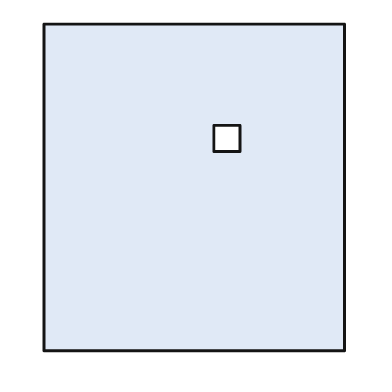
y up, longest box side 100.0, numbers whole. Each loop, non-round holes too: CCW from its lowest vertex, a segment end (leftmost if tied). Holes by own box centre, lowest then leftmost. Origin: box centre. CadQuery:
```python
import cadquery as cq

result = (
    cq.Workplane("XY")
    .moveTo(-46.0, -50.0)
    .lineTo(46.0, -50.0)
    .lineTo(46.0, 50.0)
    .lineTo(-46.0, 50.0)
    .close()
    .moveTo(6.0, 11.0)
    .lineTo(14.0, 11.0)
    .lineTo(14.0, 19.0)
    .lineTo(6.0, 19.0)
    .close()
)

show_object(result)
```